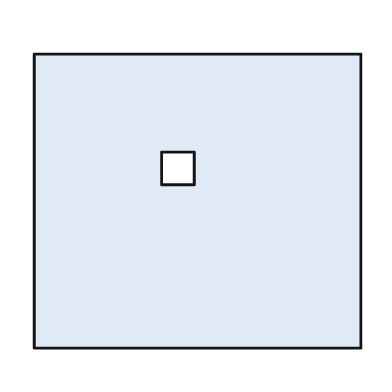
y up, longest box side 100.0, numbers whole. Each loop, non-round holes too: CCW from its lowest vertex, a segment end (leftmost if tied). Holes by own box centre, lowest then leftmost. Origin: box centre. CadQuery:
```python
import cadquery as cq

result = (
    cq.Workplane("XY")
    .moveTo(-50.0, -45.0)
    .lineTo(50.0, -45.0)
    .lineTo(50.0, 45.0)
    .lineTo(-50.0, 45.0)
    .close()
    .moveTo(-11.0, 5.0)
    .lineTo(-1.0, 5.0)
    .lineTo(-1.0, 15.0)
    .lineTo(-11.0, 15.0)
    .close()
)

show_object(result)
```